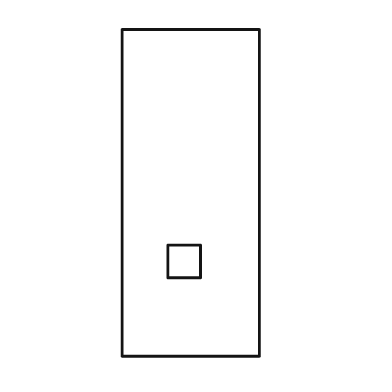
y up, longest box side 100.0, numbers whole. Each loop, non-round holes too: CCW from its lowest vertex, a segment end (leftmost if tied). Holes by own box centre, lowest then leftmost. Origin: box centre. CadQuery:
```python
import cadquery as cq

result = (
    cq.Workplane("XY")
    .moveTo(-21.0, -50.0)
    .lineTo(21.0, -50.0)
    .lineTo(21.0, 50.0)
    .lineTo(-21.0, 50.0)
    .close()
    .moveTo(-7.0, -26.0)
    .lineTo(3.0, -26.0)
    .lineTo(3.0, -16.0)
    .lineTo(-7.0, -16.0)
    .close()
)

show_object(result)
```